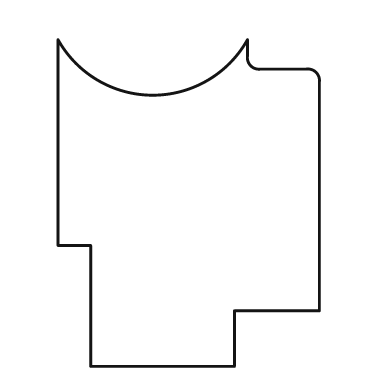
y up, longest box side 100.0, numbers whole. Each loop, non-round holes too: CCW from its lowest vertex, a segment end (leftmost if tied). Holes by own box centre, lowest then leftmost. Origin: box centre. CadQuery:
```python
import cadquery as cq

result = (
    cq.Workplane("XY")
    .moveTo(-30.0, -50.0)
    .lineTo(14.0, -50.0)
    .lineTo(14.0, -33.0)
    .lineTo(40.0, -33.0)
    .lineTo(40.0, 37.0)
    .threePointArc((39.0, 40.0), (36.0, 41.0))
    .lineTo(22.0, 41.0)
    .threePointArc((19.0, 42.0), (18.0, 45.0))
    .lineTo(18.0, 50.0)
    .threePointArc((-11.0, 33.0), (-40.0, 50.0))
    .lineTo(-40.0, -13.0)
    .lineTo(-30.0, -13.0)
    .close()
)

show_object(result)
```